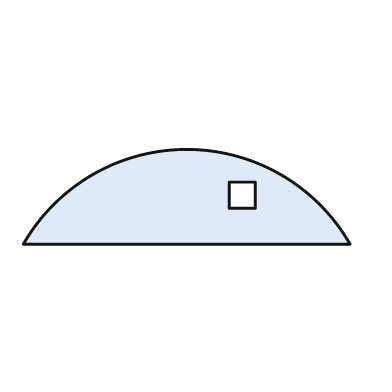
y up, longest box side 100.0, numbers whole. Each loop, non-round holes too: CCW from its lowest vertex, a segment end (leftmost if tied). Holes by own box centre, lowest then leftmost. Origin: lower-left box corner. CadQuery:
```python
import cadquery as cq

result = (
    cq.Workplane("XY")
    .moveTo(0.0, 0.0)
    .lineTo(100.0, 0.0)
    .threePointArc((50.0, 29.0), (0.0, 0.0))
    .close()
    .moveTo(63.0, 11.0)
    .lineTo(71.0, 11.0)
    .lineTo(71.0, 19.0)
    .lineTo(63.0, 19.0)
    .close()
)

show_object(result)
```